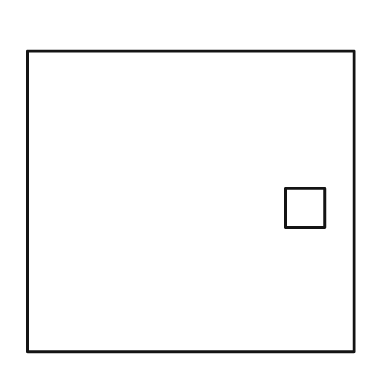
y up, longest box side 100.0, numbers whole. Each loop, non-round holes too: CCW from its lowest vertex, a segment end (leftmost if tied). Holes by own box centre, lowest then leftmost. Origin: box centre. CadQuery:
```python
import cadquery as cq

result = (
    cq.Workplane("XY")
    .moveTo(-50.0, -46.0)
    .lineTo(50.0, -46.0)
    .lineTo(50.0, 46.0)
    .lineTo(-50.0, 46.0)
    .close()
    .moveTo(29.0, -8.0)
    .lineTo(41.0, -8.0)
    .lineTo(41.0, 4.0)
    .lineTo(29.0, 4.0)
    .close()
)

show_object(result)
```